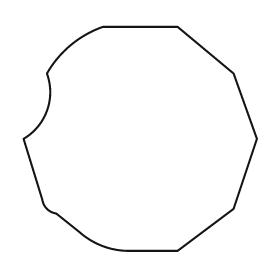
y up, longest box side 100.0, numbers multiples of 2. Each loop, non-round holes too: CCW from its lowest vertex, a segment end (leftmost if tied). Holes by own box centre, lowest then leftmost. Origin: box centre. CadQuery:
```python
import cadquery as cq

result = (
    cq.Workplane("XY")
    .moveTo(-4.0, -48.0)
    .lineTo(16.0, -48.0)
    .lineTo(40.0, -30.0)
    .lineTo(50.0, 0.0)
    .lineTo(40.0, 28.0)
    .lineTo(16.0, 48.0)
    .lineTo(-16.0, 48.0)
    .threePointArc((-30.0, 40.0), (-40.0, 28.0))
    .threePointArc((-40.0, 12.0), (-50.0, 0.0))
    .lineTo(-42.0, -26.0)
    .threePointArc((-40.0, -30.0), (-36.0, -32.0))
    .lineTo(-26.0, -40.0)
    .threePointArc((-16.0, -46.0), (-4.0, -48.0))
    .close()
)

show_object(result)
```